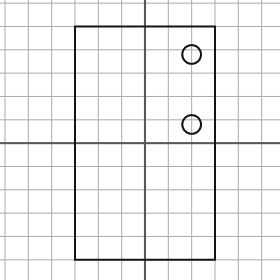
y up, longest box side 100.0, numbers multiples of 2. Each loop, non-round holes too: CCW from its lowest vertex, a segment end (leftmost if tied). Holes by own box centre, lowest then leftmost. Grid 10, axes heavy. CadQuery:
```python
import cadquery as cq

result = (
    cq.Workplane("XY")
    .moveTo(-30.0, -50.0)
    .lineTo(30.0, -50.0)
    .lineTo(30.0, 50.0)
    .lineTo(-30.0, 50.0)
    .close()
    .moveTo(20.0, 8.0)
    .circle(4.0)
    .moveTo(20.0, 38.0)
    .circle(4.0)
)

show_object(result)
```